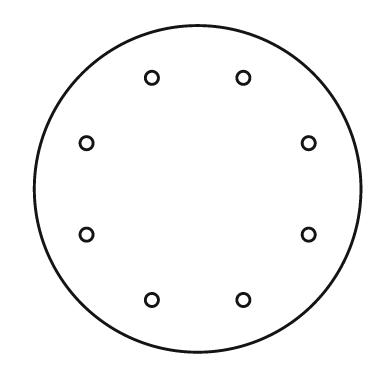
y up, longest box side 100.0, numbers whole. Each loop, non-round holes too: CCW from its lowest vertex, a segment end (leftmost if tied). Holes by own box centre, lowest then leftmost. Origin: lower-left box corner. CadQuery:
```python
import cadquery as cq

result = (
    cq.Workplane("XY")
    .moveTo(50.0, 50.0)
    .circle(50.0)
    .moveTo(36.0, 16.0)
    .circle(2.0)
    .moveTo(64.0, 16.0)
    .circle(2.0)
    .moveTo(16.0, 36.0)
    .circle(2.0)
    .moveTo(84.0, 36.0)
    .circle(2.0)
    .moveTo(16.0, 64.0)
    .circle(2.0)
    .moveTo(84.0, 64.0)
    .circle(2.0)
    .moveTo(36.0, 84.0)
    .circle(2.0)
    .moveTo(64.0, 84.0)
    .circle(2.0)
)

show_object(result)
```